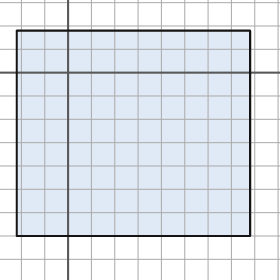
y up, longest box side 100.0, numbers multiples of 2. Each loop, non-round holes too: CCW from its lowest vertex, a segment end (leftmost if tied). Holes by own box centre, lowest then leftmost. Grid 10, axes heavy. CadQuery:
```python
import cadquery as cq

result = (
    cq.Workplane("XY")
    .moveTo(-22.0, -70.0)
    .lineTo(78.0, -70.0)
    .lineTo(78.0, 18.0)
    .lineTo(-22.0, 18.0)
    .close()
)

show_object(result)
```